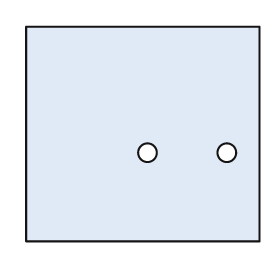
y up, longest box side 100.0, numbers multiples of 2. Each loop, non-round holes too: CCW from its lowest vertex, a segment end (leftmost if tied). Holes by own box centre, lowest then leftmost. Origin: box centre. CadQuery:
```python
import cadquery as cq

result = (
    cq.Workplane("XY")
    .moveTo(-50.0, -46.0)
    .lineTo(50.0, -46.0)
    .lineTo(50.0, 46.0)
    .lineTo(-50.0, 46.0)
    .close()
    .moveTo(2.0, -8.0)
    .circle(4.0)
    .moveTo(36.0, -8.0)
    .circle(4.0)
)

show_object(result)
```